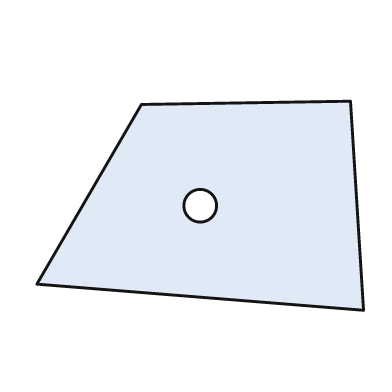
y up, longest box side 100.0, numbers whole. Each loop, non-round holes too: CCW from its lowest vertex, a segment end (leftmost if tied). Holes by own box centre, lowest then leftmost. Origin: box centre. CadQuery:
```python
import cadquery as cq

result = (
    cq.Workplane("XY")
    .moveTo(50.0, -32.0)
    .lineTo(46.0, 32.0)
    .lineTo(-18.0, 31.0)
    .lineTo(-50.0, -24.0)
    .close()
    .moveTo(0.0, 0.0)
    .circle(5.0)
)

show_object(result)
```